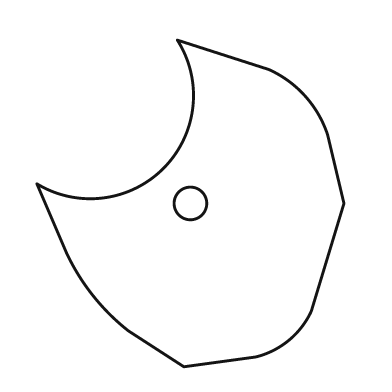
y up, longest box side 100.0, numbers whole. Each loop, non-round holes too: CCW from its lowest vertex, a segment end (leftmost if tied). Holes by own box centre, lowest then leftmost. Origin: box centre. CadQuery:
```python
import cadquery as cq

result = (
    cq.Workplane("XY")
    .moveTo(-2.0, -50.0)
    .lineTo(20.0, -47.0)
    .threePointArc((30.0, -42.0), (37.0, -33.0))
    .lineTo(47.0, 0.0)
    .lineTo(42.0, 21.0)
    .threePointArc((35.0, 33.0), (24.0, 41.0))
    .lineTo(-4.0, 50.0)
    .threePointArc((-8.0, 11.0), (-47.0, 6.0))
    .lineTo(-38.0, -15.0)
    .threePointArc((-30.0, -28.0), (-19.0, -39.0))
    .close()
    .moveTo(0.0, 0.0)
    .circle(5.0)
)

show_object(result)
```